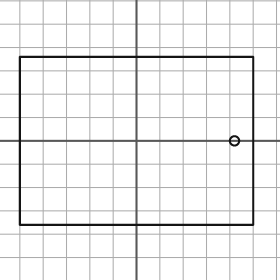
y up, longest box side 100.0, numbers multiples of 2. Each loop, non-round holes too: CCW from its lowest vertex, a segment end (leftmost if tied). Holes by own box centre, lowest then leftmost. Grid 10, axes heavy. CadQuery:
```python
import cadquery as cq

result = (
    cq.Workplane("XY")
    .moveTo(-50.0, -36.0)
    .lineTo(50.0, -36.0)
    .lineTo(50.0, 36.0)
    .lineTo(-50.0, 36.0)
    .close()
    .moveTo(42.0, 0.0)
    .circle(2.0)
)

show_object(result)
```